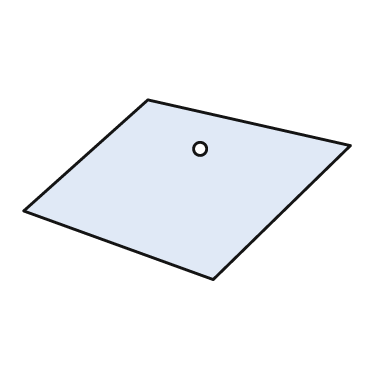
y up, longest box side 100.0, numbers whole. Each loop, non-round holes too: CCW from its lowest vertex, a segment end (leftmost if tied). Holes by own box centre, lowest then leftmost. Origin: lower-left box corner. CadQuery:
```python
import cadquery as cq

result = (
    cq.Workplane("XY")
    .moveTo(58.0, 0.0)
    .lineTo(100.0, 41.0)
    .lineTo(38.0, 55.0)
    .lineTo(0.0, 21.0)
    .close()
    .moveTo(54.0, 40.0)
    .circle(2.0)
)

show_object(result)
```